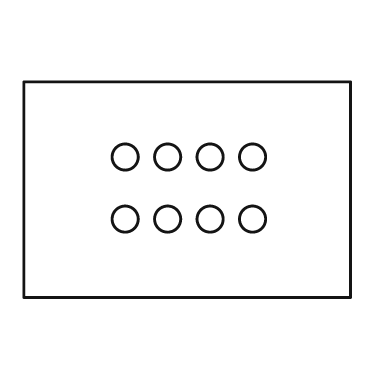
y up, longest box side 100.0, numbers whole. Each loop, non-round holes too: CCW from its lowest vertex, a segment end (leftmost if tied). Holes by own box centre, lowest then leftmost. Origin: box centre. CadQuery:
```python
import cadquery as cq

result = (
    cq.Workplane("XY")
    .moveTo(-50.0, -33.0)
    .lineTo(50.0, -33.0)
    .lineTo(50.0, 33.0)
    .lineTo(-50.0, 33.0)
    .close()
    .moveTo(-19.0, -9.0)
    .circle(4.0)
    .moveTo(-6.0, -9.0)
    .circle(4.0)
    .moveTo(7.0, -9.0)
    .circle(4.0)
    .moveTo(20.0, -9.0)
    .circle(4.0)
    .moveTo(-19.0, 10.0)
    .circle(4.0)
    .moveTo(-6.0, 10.0)
    .circle(4.0)
    .moveTo(7.0, 10.0)
    .circle(4.0)
    .moveTo(20.0, 10.0)
    .circle(4.0)
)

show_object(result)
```